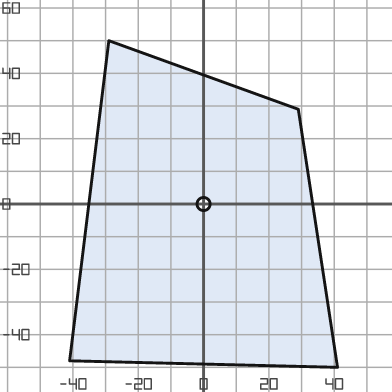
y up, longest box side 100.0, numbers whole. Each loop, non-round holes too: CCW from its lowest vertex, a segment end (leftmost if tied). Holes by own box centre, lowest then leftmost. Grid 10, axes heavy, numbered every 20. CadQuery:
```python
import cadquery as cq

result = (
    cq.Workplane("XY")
    .moveTo(41.0, -50.0)
    .lineTo(29.0, 29.0)
    .lineTo(-29.0, 50.0)
    .lineTo(-41.0, -48.0)
    .close()
    .moveTo(0.0, 0.0)
    .circle(2.0)
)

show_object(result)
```